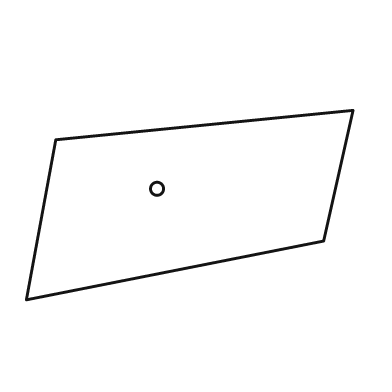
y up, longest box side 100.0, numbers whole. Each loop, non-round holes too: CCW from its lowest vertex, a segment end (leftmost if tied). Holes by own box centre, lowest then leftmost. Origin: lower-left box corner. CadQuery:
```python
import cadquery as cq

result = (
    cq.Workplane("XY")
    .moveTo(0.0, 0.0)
    .lineTo(91.0, 18.0)
    .lineTo(100.0, 58.0)
    .lineTo(9.0, 49.0)
    .close()
    .moveTo(40.0, 34.0)
    .circle(2.0)
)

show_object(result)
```